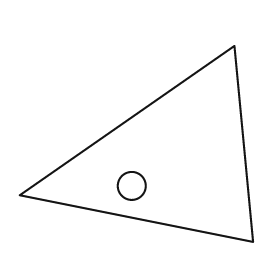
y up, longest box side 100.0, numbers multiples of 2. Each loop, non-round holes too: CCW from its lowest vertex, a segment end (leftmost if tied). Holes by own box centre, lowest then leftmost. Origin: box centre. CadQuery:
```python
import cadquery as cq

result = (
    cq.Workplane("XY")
    .moveTo(50.0, -42.0)
    .lineTo(42.0, 42.0)
    .lineTo(-50.0, -22.0)
    .close()
    .moveTo(-2.0, -18.0)
    .circle(6.0)
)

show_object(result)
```